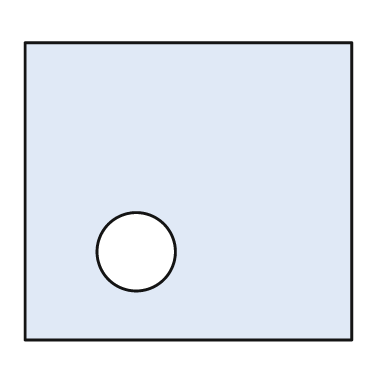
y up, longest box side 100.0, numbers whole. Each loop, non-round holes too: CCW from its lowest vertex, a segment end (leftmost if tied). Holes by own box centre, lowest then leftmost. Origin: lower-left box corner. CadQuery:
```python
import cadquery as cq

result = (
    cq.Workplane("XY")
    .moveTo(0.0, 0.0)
    .lineTo(100.0, 0.0)
    .lineTo(100.0, 91.0)
    .lineTo(0.0, 91.0)
    .close()
    .moveTo(34.0, 27.0)
    .circle(12.0)
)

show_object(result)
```